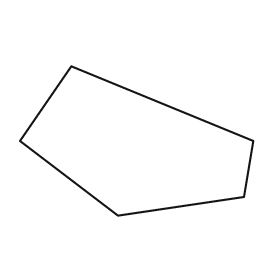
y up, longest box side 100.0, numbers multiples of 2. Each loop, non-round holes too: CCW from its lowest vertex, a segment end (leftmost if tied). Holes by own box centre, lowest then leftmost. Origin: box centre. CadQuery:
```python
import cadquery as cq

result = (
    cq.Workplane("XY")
    .moveTo(-8.0, -32.0)
    .lineTo(46.0, -24.0)
    .lineTo(50.0, 0.0)
    .lineTo(-28.0, 32.0)
    .lineTo(-50.0, 0.0)
    .close()
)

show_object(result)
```